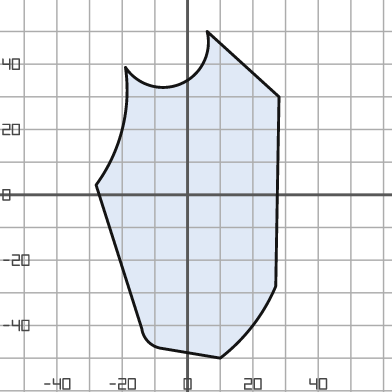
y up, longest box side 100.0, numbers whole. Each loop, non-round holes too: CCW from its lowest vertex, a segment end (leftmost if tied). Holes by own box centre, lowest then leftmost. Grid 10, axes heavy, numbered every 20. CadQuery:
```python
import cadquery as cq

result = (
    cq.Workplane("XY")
    .moveTo(10.0, -50.0)
    .threePointArc((20.0, -40.0), (27.0, -28.0))
    .lineTo(28.0, 30.0)
    .lineTo(6.0, 50.0)
    .threePointArc((-2.0, 34.0), (-19.0, 39.0))
    .threePointArc((-20.0, 20.0), (-28.0, 3.0))
    .lineTo(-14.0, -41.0)
    .threePointArc((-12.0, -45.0), (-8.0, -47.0))
    .close()
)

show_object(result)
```